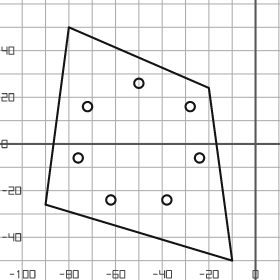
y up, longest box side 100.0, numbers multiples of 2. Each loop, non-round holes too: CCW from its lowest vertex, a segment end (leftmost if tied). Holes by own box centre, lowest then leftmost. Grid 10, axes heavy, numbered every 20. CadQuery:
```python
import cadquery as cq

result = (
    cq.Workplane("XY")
    .moveTo(-10.0, -50.0)
    .lineTo(-20.0, 24.0)
    .lineTo(-80.0, 50.0)
    .lineTo(-90.0, -26.0)
    .close()
    .moveTo(-62.0, -24.0)
    .circle(2.0)
    .moveTo(-38.0, -24.0)
    .circle(2.0)
    .moveTo(-76.0, -6.0)
    .circle(2.0)
    .moveTo(-24.0, -6.0)
    .circle(2.0)
    .moveTo(-72.0, 16.0)
    .circle(2.0)
    .moveTo(-28.0, 16.0)
    .circle(2.0)
    .moveTo(-50.0, 26.0)
    .circle(2.0)
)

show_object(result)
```